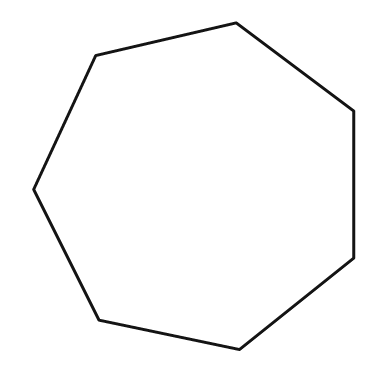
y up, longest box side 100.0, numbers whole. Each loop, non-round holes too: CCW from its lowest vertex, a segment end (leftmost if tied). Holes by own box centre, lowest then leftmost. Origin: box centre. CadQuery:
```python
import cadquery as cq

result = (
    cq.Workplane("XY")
    .moveTo(14.0, -50.0)
    .lineTo(49.0, -22.0)
    .lineTo(49.0, 23.0)
    .lineTo(13.0, 50.0)
    .lineTo(-30.0, 40.0)
    .lineTo(-49.0, -1.0)
    .lineTo(-29.0, -41.0)
    .close()
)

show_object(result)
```